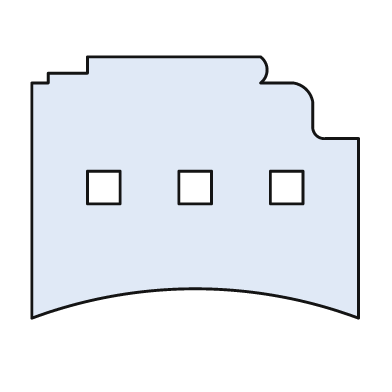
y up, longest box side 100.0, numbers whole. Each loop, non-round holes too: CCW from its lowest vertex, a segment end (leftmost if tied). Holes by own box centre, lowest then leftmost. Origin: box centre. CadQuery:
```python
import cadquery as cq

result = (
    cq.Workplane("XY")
    .moveTo(-50.0, -40.0)
    .threePointArc((0.0, -31.0), (50.0, -40.0))
    .lineTo(50.0, 15.0)
    .lineTo(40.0, 15.0)
    .threePointArc((37.0, 16.0), (36.0, 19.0))
    .lineTo(36.0, 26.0)
    .threePointArc((34.0, 30.0), (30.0, 32.0))
    .lineTo(20.0, 32.0)
    .threePointArc((22.0, 36.0), (20.0, 40.0))
    .lineTo(-33.0, 40.0)
    .lineTo(-33.0, 35.0)
    .lineTo(-45.0, 35.0)
    .lineTo(-45.0, 32.0)
    .lineTo(-50.0, 32.0)
    .close()
    .moveTo(-33.0, -5.0)
    .lineTo(-23.0, -5.0)
    .lineTo(-23.0, 5.0)
    .lineTo(-33.0, 5.0)
    .close()
    .moveTo(-5.0, -5.0)
    .lineTo(5.0, -5.0)
    .lineTo(5.0, 5.0)
    .lineTo(-5.0, 5.0)
    .close()
    .moveTo(23.0, -5.0)
    .lineTo(33.0, -5.0)
    .lineTo(33.0, 5.0)
    .lineTo(23.0, 5.0)
    .close()
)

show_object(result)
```